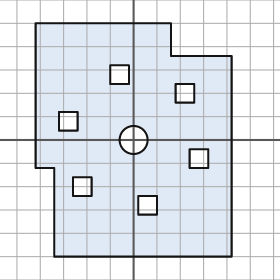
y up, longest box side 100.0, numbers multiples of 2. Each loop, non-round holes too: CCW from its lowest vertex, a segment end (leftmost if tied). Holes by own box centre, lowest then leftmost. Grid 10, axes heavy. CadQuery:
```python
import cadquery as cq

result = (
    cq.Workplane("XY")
    .moveTo(-34.0, -50.0)
    .lineTo(42.0, -50.0)
    .lineTo(42.0, 36.0)
    .lineTo(16.0, 36.0)
    .lineTo(16.0, 50.0)
    .lineTo(-42.0, 50.0)
    .lineTo(-42.0, -12.0)
    .lineTo(-34.0, -12.0)
    .close()
    .moveTo(2.0, -32.0)
    .lineTo(10.0, -32.0)
    .lineTo(10.0, -24.0)
    .lineTo(2.0, -24.0)
    .close()
    .moveTo(-26.0, -24.0)
    .lineTo(-18.0, -24.0)
    .lineTo(-18.0, -16.0)
    .lineTo(-26.0, -16.0)
    .close()
    .moveTo(24.0, -12.0)
    .lineTo(32.0, -12.0)
    .lineTo(32.0, -4.0)
    .lineTo(24.0, -4.0)
    .close()
    .moveTo(0.0, 0.0)
    .circle(6.0)
    .moveTo(-32.0, 4.0)
    .lineTo(-24.0, 4.0)
    .lineTo(-24.0, 12.0)
    .lineTo(-32.0, 12.0)
    .close()
    .moveTo(18.0, 16.0)
    .lineTo(26.0, 16.0)
    .lineTo(26.0, 24.0)
    .lineTo(18.0, 24.0)
    .close()
    .moveTo(-10.0, 24.0)
    .lineTo(-2.0, 24.0)
    .lineTo(-2.0, 32.0)
    .lineTo(-10.0, 32.0)
    .close()
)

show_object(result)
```